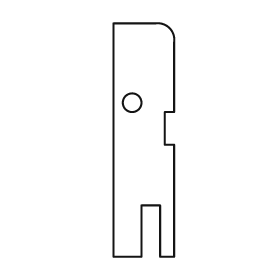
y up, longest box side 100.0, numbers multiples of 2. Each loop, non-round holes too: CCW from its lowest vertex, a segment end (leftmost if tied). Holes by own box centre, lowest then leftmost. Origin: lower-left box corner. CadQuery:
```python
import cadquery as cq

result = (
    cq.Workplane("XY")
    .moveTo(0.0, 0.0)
    .lineTo(12.0, 0.0)
    .lineTo(12.0, 22.0)
    .lineTo(20.0, 22.0)
    .lineTo(20.0, 0.0)
    .lineTo(26.0, 0.0)
    .lineTo(26.0, 48.0)
    .lineTo(22.0, 48.0)
    .lineTo(22.0, 62.0)
    .lineTo(26.0, 62.0)
    .lineTo(26.0, 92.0)
    .threePointArc((24.0, 98.0), (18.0, 100.0))
    .lineTo(0.0, 100.0)
    .close()
    .moveTo(8.0, 66.0)
    .circle(4.0)
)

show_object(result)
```